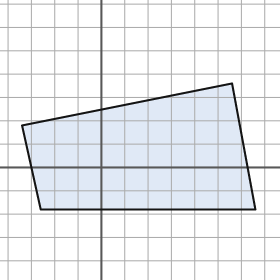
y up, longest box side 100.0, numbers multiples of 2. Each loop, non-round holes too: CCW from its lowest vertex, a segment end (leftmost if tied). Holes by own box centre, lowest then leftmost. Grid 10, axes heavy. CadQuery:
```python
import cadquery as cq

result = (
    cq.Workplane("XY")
    .moveTo(-26.0, -18.0)
    .lineTo(66.0, -18.0)
    .lineTo(56.0, 36.0)
    .lineTo(-34.0, 18.0)
    .close()
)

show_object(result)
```